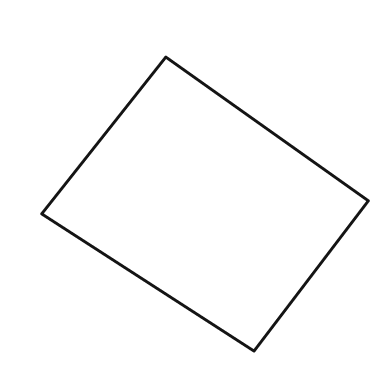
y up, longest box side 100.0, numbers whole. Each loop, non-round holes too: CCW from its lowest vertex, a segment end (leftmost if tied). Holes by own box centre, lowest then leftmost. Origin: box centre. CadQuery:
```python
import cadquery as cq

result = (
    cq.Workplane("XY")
    .moveTo(15.0, -45.0)
    .lineTo(50.0, 1.0)
    .lineTo(-12.0, 45.0)
    .lineTo(-50.0, -3.0)
    .close()
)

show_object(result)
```